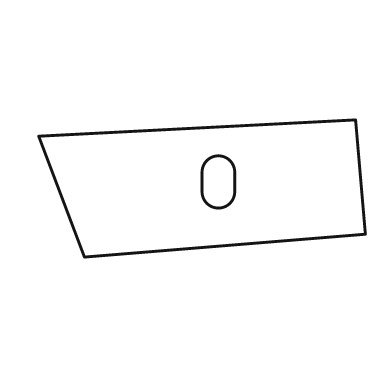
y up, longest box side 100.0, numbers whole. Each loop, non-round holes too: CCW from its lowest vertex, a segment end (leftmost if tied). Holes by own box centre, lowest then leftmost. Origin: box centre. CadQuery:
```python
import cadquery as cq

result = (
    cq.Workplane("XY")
    .moveTo(-36.0, -21.0)
    .lineTo(50.0, -14.0)
    .lineTo(47.0, 21.0)
    .lineTo(-50.0, 16.0)
    .close()
    .moveTo(0.0, -1.0)
    .threePointArc((5.0, -6.0), (10.0, -1.0))
    .lineTo(10.0, 5.0)
    .threePointArc((5.0, 10.0), (0.0, 5.0))
    .close()
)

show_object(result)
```